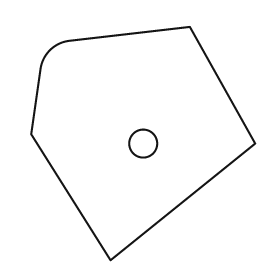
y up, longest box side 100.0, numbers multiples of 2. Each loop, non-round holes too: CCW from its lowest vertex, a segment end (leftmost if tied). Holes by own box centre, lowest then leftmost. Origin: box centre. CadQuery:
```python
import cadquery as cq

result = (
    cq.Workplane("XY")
    .moveTo(-14.0, -50.0)
    .lineTo(48.0, 0.0)
    .lineTo(20.0, 50.0)
    .lineTo(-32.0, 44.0)
    .threePointArc((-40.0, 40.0), (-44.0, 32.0))
    .lineTo(-48.0, 4.0)
    .close()
    .moveTo(0.0, 0.0)
    .circle(6.0)
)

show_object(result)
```